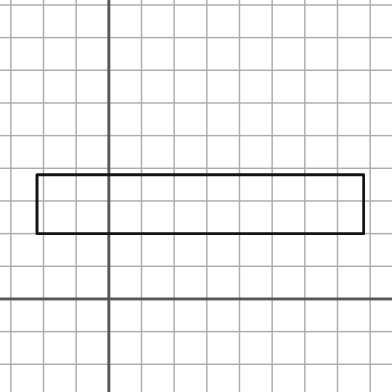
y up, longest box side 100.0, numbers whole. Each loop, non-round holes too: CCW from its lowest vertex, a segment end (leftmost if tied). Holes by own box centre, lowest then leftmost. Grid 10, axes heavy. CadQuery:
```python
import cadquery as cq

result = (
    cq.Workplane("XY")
    .moveTo(-22.0, 20.0)
    .lineTo(78.0, 20.0)
    .lineTo(78.0, 38.0)
    .lineTo(-22.0, 38.0)
    .close()
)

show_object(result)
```